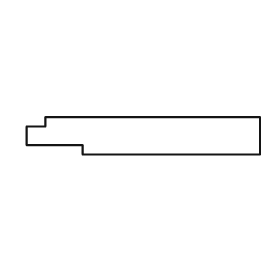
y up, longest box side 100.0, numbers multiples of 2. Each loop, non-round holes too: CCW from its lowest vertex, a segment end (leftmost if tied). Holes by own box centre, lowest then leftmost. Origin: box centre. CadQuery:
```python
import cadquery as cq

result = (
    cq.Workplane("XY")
    .moveTo(-26.0, -8.0)
    .lineTo(50.0, -8.0)
    .lineTo(50.0, 8.0)
    .lineTo(-42.0, 8.0)
    .lineTo(-42.0, 4.0)
    .lineTo(-50.0, 4.0)
    .lineTo(-50.0, -4.0)
    .lineTo(-26.0, -4.0)
    .close()
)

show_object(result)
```